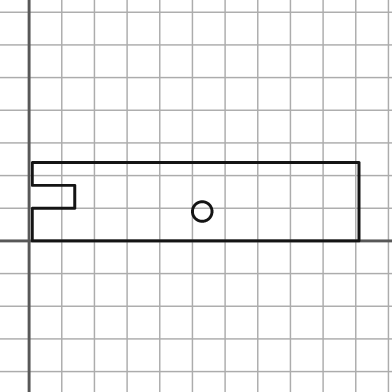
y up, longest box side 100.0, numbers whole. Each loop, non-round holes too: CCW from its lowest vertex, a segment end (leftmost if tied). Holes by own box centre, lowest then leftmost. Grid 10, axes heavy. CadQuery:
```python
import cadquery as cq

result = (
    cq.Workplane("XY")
    .moveTo(1.0, 0.0)
    .lineTo(101.0, 0.0)
    .lineTo(101.0, 24.0)
    .lineTo(1.0, 24.0)
    .lineTo(1.0, 17.0)
    .lineTo(14.0, 17.0)
    .lineTo(14.0, 10.0)
    .lineTo(1.0, 10.0)
    .close()
    .moveTo(53.0, 9.0)
    .circle(3.0)
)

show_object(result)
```